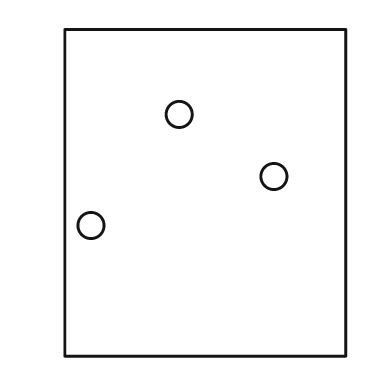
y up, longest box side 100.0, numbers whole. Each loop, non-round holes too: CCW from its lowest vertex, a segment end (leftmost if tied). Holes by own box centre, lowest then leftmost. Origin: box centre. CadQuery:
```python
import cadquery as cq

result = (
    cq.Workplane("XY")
    .moveTo(-43.0, -50.0)
    .lineTo(43.0, -50.0)
    .lineTo(43.0, 50.0)
    .lineTo(-43.0, 50.0)
    .close()
    .moveTo(-35.0, -10.0)
    .circle(4.0)
    .moveTo(21.0, 5.0)
    .circle(4.0)
    .moveTo(-8.0, 24.0)
    .circle(4.0)
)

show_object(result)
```